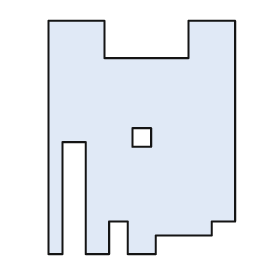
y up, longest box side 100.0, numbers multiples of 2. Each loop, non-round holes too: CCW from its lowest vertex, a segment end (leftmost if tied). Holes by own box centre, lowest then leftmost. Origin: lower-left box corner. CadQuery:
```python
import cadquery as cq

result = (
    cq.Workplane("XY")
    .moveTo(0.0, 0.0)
    .lineTo(6.0, 0.0)
    .lineTo(6.0, 48.0)
    .lineTo(16.0, 48.0)
    .lineTo(16.0, 0.0)
    .lineTo(26.0, 0.0)
    .lineTo(26.0, 14.0)
    .lineTo(34.0, 14.0)
    .lineTo(34.0, 0.0)
    .lineTo(46.0, 0.0)
    .lineTo(46.0, 8.0)
    .lineTo(70.0, 8.0)
    .lineTo(70.0, 14.0)
    .lineTo(80.0, 14.0)
    .lineTo(80.0, 100.0)
    .lineTo(60.0, 100.0)
    .lineTo(60.0, 84.0)
    .lineTo(24.0, 84.0)
    .lineTo(24.0, 100.0)
    .lineTo(0.0, 100.0)
    .close()
    .moveTo(36.0, 46.0)
    .lineTo(44.0, 46.0)
    .lineTo(44.0, 54.0)
    .lineTo(36.0, 54.0)
    .close()
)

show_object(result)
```